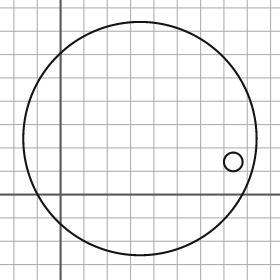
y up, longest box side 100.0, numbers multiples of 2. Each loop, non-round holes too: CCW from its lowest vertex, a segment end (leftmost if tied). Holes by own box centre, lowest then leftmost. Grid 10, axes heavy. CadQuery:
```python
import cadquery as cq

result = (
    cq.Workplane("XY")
    .moveTo(34.0, 24.0)
    .circle(50.0)
    .moveTo(74.0, 14.0)
    .circle(4.0)
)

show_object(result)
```